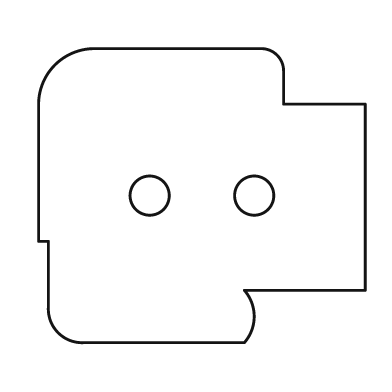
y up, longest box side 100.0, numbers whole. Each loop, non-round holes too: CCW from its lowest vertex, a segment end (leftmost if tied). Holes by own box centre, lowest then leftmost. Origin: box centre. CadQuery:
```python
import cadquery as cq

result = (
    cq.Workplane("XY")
    .moveTo(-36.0, -45.0)
    .lineTo(13.0, -45.0)
    .threePointArc((16.0, -37.0), (13.0, -29.0))
    .lineTo(50.0, -29.0)
    .lineTo(50.0, 28.0)
    .lineTo(25.0, 28.0)
    .lineTo(25.0, 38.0)
    .threePointArc((23.0, 43.0), (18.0, 45.0))
    .lineTo(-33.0, 45.0)
    .threePointArc((-45.0, 40.0), (-50.0, 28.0))
    .lineTo(-50.0, -14.0)
    .lineTo(-47.0, -14.0)
    .lineTo(-47.0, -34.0)
    .threePointArc((-44.0, -42.0), (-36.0, -45.0))
    .close()
    .moveTo(-16.0, 0.0)
    .circle(6.0)
    .moveTo(16.0, 0.0)
    .circle(6.0)
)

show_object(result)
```